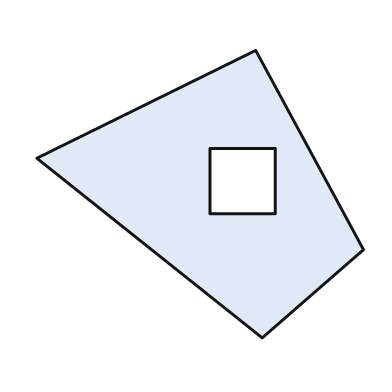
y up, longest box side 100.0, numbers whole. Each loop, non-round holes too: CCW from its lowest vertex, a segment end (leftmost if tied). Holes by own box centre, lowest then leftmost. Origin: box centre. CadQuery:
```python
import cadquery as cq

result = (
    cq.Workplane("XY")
    .moveTo(19.0, -44.0)
    .lineTo(50.0, -17.0)
    .lineTo(17.0, 44.0)
    .lineTo(-50.0, 11.0)
    .close()
    .moveTo(3.0, -6.0)
    .lineTo(23.0, -6.0)
    .lineTo(23.0, 14.0)
    .lineTo(3.0, 14.0)
    .close()
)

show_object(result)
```